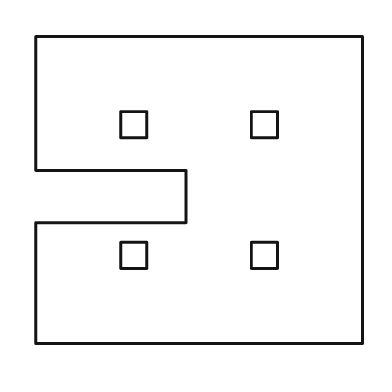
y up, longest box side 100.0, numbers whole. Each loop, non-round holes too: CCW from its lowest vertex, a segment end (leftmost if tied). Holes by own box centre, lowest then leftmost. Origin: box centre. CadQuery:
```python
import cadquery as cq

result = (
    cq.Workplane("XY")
    .moveTo(-50.0, -47.0)
    .lineTo(50.0, -47.0)
    .lineTo(50.0, 47.0)
    .lineTo(-50.0, 47.0)
    .lineTo(-50.0, 6.0)
    .lineTo(-4.0, 6.0)
    .lineTo(-4.0, -10.0)
    .lineTo(-50.0, -10.0)
    .close()
    .moveTo(-24.0, -24.0)
    .lineTo(-16.0, -24.0)
    .lineTo(-16.0, -16.0)
    .lineTo(-24.0, -16.0)
    .close()
    .moveTo(16.0, -24.0)
    .lineTo(24.0, -24.0)
    .lineTo(24.0, -16.0)
    .lineTo(16.0, -16.0)
    .close()
    .moveTo(-24.0, 16.0)
    .lineTo(-16.0, 16.0)
    .lineTo(-16.0, 24.0)
    .lineTo(-24.0, 24.0)
    .close()
    .moveTo(16.0, 16.0)
    .lineTo(24.0, 16.0)
    .lineTo(24.0, 24.0)
    .lineTo(16.0, 24.0)
    .close()
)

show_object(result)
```